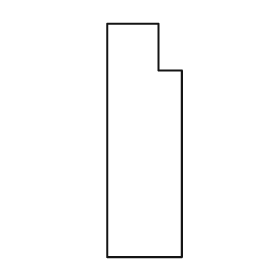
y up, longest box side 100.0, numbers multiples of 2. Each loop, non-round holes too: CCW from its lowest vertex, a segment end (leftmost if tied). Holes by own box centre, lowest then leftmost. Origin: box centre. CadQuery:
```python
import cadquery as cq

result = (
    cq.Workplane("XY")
    .moveTo(-16.0, -50.0)
    .lineTo(16.0, -50.0)
    .lineTo(16.0, 30.0)
    .lineTo(6.0, 30.0)
    .lineTo(6.0, 50.0)
    .lineTo(-16.0, 50.0)
    .close()
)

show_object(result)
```